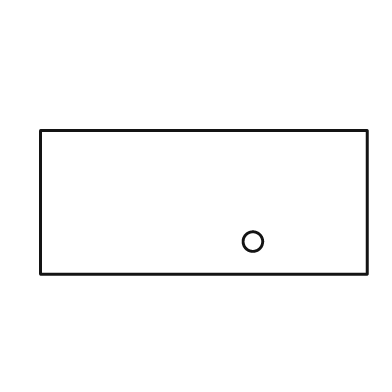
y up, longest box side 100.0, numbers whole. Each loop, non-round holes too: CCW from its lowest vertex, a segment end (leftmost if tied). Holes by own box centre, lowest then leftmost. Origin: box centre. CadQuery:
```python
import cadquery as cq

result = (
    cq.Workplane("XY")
    .moveTo(-50.0, -22.0)
    .lineTo(50.0, -22.0)
    .lineTo(50.0, 22.0)
    .lineTo(-50.0, 22.0)
    .close()
    .moveTo(15.0, -12.0)
    .circle(3.0)
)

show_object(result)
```